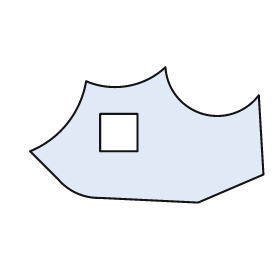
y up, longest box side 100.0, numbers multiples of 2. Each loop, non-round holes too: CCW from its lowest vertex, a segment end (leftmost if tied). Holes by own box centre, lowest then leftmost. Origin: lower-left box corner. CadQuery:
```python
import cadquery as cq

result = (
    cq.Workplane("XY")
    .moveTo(72.0, 0.0)
    .lineTo(100.0, 12.0)
    .lineTo(98.0, 46.0)
    .threePointArc((74.0, 38.0), (58.0, 58.0))
    .threePointArc((42.0, 50.0), (24.0, 52.0))
    .threePointArc((16.0, 34.0), (0.0, 22.0))
    .lineTo(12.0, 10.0)
    .threePointArc((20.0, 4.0), (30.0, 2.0))
    .close()
    .moveTo(30.0, 22.0)
    .lineTo(46.0, 22.0)
    .lineTo(46.0, 38.0)
    .lineTo(30.0, 38.0)
    .close()
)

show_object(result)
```